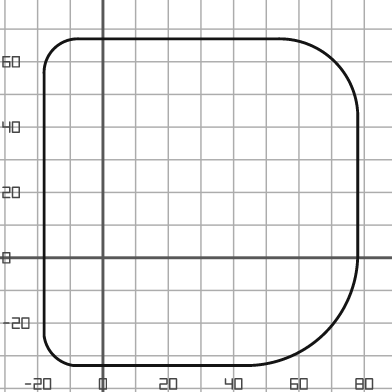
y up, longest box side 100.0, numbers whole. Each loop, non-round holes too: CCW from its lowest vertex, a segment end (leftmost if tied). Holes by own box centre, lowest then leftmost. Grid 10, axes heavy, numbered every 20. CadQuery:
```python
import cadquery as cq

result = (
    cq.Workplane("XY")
    .moveTo(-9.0, -33.0)
    .lineTo(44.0, -33.0)
    .threePointArc((68.0, -23.0), (78.0, 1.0))
    .lineTo(78.0, 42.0)
    .threePointArc((71.0, 60.0), (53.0, 67.0))
    .lineTo(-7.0, 67.0)
    .threePointArc((-15.0, 64.0), (-18.0, 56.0))
    .lineTo(-18.0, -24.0)
    .threePointArc((-15.0, -30.0), (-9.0, -33.0))
    .close()
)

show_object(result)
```